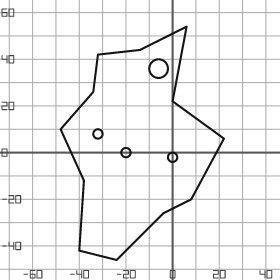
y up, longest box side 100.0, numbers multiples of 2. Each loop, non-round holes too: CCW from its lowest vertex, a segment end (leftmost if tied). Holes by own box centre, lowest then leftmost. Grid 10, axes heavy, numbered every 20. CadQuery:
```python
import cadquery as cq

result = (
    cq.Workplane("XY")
    .moveTo(-24.0, -46.0)
    .lineTo(-4.0, -26.0)
    .lineTo(8.0, -20.0)
    .lineTo(22.0, 6.0)
    .lineTo(0.0, 22.0)
    .lineTo(6.0, 54.0)
    .lineTo(-14.0, 44.0)
    .lineTo(-32.0, 42.0)
    .lineTo(-34.0, 26.0)
    .lineTo(-48.0, 10.0)
    .lineTo(-38.0, -12.0)
    .lineTo(-40.0, -42.0)
    .close()
    .moveTo(0.0, -2.0)
    .circle(2.0)
    .moveTo(-20.0, 0.0)
    .circle(2.0)
    .moveTo(-32.0, 8.0)
    .circle(2.0)
    .moveTo(-6.0, 36.0)
    .circle(4.0)
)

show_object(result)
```